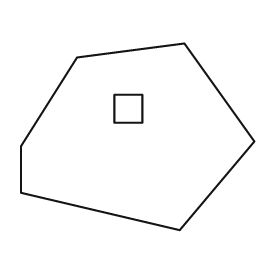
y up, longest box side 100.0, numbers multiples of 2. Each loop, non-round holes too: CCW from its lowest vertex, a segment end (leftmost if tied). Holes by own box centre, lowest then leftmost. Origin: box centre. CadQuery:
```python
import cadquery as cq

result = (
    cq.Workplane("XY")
    .moveTo(18.0, -40.0)
    .lineTo(50.0, -2.0)
    .lineTo(20.0, 40.0)
    .lineTo(-26.0, 34.0)
    .lineTo(-50.0, -4.0)
    .lineTo(-50.0, -24.0)
    .close()
    .moveTo(-10.0, 6.0)
    .lineTo(2.0, 6.0)
    .lineTo(2.0, 18.0)
    .lineTo(-10.0, 18.0)
    .close()
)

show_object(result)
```